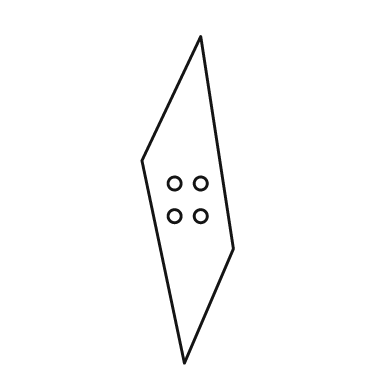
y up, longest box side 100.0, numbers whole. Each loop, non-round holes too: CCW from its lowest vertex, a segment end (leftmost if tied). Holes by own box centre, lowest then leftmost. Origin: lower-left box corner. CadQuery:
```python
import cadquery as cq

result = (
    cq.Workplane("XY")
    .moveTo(13.0, 0.0)
    .lineTo(28.0, 35.0)
    .lineTo(18.0, 100.0)
    .lineTo(0.0, 62.0)
    .close()
    .moveTo(10.0, 45.0)
    .circle(2.0)
    .moveTo(18.0, 45.0)
    .circle(2.0)
    .moveTo(10.0, 55.0)
    .circle(2.0)
    .moveTo(18.0, 55.0)
    .circle(2.0)
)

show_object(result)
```